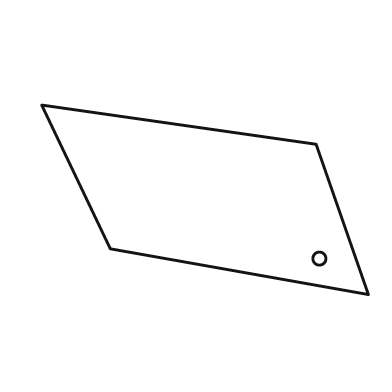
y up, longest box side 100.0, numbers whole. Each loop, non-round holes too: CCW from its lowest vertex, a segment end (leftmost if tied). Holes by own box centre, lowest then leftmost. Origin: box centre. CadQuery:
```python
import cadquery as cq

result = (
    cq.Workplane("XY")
    .moveTo(50.0, -29.0)
    .lineTo(34.0, 17.0)
    .lineTo(-50.0, 29.0)
    .lineTo(-29.0, -15.0)
    .close()
    .moveTo(35.0, -18.0)
    .circle(2.0)
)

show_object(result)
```